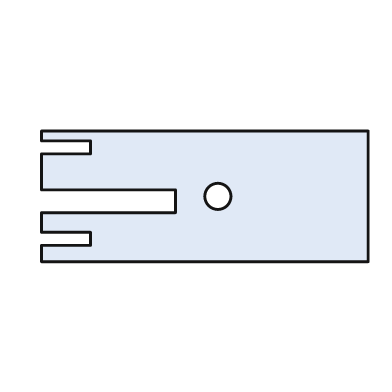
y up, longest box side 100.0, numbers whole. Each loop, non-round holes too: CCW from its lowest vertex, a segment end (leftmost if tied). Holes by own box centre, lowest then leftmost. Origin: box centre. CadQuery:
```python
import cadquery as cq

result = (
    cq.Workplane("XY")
    .moveTo(-50.0, -20.0)
    .lineTo(50.0, -20.0)
    .lineTo(50.0, 20.0)
    .lineTo(-50.0, 20.0)
    .lineTo(-50.0, 17.0)
    .lineTo(-35.0, 17.0)
    .lineTo(-35.0, 13.0)
    .lineTo(-50.0, 13.0)
    .lineTo(-50.0, 2.0)
    .lineTo(-9.0, 2.0)
    .lineTo(-9.0, -5.0)
    .lineTo(-50.0, -5.0)
    .lineTo(-50.0, -11.0)
    .lineTo(-35.0, -11.0)
    .lineTo(-35.0, -15.0)
    .lineTo(-50.0, -15.0)
    .close()
    .moveTo(4.0, 0.0)
    .circle(4.0)
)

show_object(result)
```